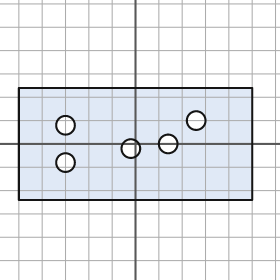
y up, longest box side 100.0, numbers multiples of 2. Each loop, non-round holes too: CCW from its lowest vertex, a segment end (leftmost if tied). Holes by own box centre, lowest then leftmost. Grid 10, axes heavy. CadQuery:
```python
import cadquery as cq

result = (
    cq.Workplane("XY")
    .moveTo(-50.0, -24.0)
    .lineTo(50.0, -24.0)
    .lineTo(50.0, 24.0)
    .lineTo(-50.0, 24.0)
    .close()
    .moveTo(-30.0, -8.0)
    .circle(4.0)
    .moveTo(-2.0, -2.0)
    .circle(4.0)
    .moveTo(14.0, 0.0)
    .circle(4.0)
    .moveTo(-30.0, 8.0)
    .circle(4.0)
    .moveTo(26.0, 10.0)
    .circle(4.0)
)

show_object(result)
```